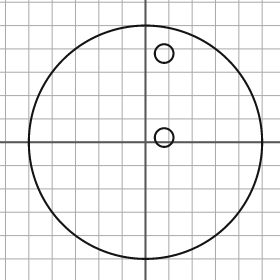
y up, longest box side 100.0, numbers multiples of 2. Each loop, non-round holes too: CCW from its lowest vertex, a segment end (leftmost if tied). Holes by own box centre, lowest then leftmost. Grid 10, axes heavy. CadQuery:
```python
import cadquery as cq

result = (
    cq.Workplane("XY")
    .moveTo(0.0, 0.0)
    .circle(50.0)
    .moveTo(8.0, 2.0)
    .circle(4.0)
    .moveTo(8.0, 38.0)
    .circle(4.0)
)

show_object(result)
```